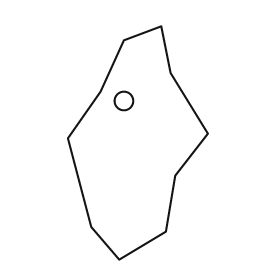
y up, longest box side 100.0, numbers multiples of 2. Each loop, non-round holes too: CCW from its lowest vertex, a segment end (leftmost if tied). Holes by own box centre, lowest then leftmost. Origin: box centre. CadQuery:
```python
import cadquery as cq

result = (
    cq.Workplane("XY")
    .moveTo(-8.0, -50.0)
    .lineTo(12.0, -38.0)
    .lineTo(16.0, -14.0)
    .lineTo(30.0, 4.0)
    .lineTo(14.0, 30.0)
    .lineTo(10.0, 50.0)
    .lineTo(-6.0, 44.0)
    .lineTo(-16.0, 22.0)
    .lineTo(-30.0, 2.0)
    .lineTo(-20.0, -36.0)
    .close()
    .moveTo(-6.0, 18.0)
    .circle(4.0)
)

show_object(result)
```